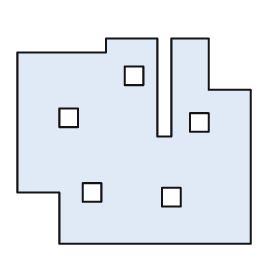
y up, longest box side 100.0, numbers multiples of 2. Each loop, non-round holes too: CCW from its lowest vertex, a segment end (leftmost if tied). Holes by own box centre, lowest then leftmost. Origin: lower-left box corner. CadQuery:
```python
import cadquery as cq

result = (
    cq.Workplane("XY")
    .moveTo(18.0, 0.0)
    .lineTo(100.0, 0.0)
    .lineTo(100.0, 66.0)
    .lineTo(82.0, 66.0)
    .lineTo(82.0, 88.0)
    .lineTo(66.0, 88.0)
    .lineTo(66.0, 46.0)
    .lineTo(60.0, 46.0)
    .lineTo(60.0, 88.0)
    .lineTo(38.0, 88.0)
    .lineTo(38.0, 82.0)
    .lineTo(0.0, 82.0)
    .lineTo(0.0, 22.0)
    .lineTo(18.0, 22.0)
    .close()
    .moveTo(62.0, 16.0)
    .lineTo(70.0, 16.0)
    .lineTo(70.0, 24.0)
    .lineTo(62.0, 24.0)
    .close()
    .moveTo(28.0, 18.0)
    .lineTo(36.0, 18.0)
    .lineTo(36.0, 26.0)
    .lineTo(28.0, 26.0)
    .close()
    .moveTo(74.0, 48.0)
    .lineTo(82.0, 48.0)
    .lineTo(82.0, 56.0)
    .lineTo(74.0, 56.0)
    .close()
    .moveTo(18.0, 50.0)
    .lineTo(26.0, 50.0)
    .lineTo(26.0, 58.0)
    .lineTo(18.0, 58.0)
    .close()
    .moveTo(46.0, 68.0)
    .lineTo(54.0, 68.0)
    .lineTo(54.0, 76.0)
    .lineTo(46.0, 76.0)
    .close()
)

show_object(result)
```